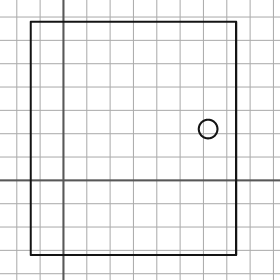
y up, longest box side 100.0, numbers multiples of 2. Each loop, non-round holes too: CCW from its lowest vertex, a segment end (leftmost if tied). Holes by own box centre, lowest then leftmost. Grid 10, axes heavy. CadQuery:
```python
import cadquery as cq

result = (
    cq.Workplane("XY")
    .moveTo(-14.0, -32.0)
    .lineTo(74.0, -32.0)
    .lineTo(74.0, 68.0)
    .lineTo(-14.0, 68.0)
    .close()
    .moveTo(62.0, 22.0)
    .circle(4.0)
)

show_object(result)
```